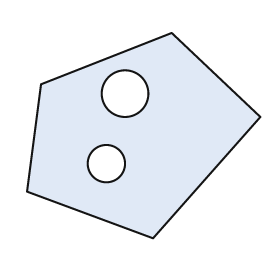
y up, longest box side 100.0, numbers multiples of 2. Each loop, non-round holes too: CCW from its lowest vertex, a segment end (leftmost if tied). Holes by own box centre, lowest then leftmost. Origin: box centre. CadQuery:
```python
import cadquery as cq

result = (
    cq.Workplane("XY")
    .moveTo(4.0, -44.0)
    .lineTo(50.0, 8.0)
    .lineTo(12.0, 44.0)
    .lineTo(-44.0, 22.0)
    .lineTo(-50.0, -24.0)
    .close()
    .moveTo(-16.0, -12.0)
    .circle(8.0)
    .moveTo(-8.0, 18.0)
    .circle(10.0)
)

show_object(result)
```